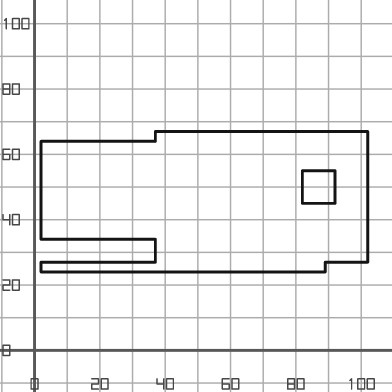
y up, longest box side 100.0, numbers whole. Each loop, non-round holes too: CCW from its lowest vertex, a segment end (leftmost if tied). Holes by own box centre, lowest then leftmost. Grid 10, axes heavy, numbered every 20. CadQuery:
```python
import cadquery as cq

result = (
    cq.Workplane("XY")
    .moveTo(2.0, 24.0)
    .lineTo(89.0, 24.0)
    .lineTo(89.0, 27.0)
    .lineTo(102.0, 27.0)
    .lineTo(102.0, 67.0)
    .lineTo(37.0, 67.0)
    .lineTo(37.0, 64.0)
    .lineTo(2.0, 64.0)
    .lineTo(2.0, 34.0)
    .lineTo(37.0, 34.0)
    .lineTo(37.0, 27.0)
    .lineTo(2.0, 27.0)
    .close()
    .moveTo(82.0, 45.0)
    .lineTo(92.0, 45.0)
    .lineTo(92.0, 55.0)
    .lineTo(82.0, 55.0)
    .close()
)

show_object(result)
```